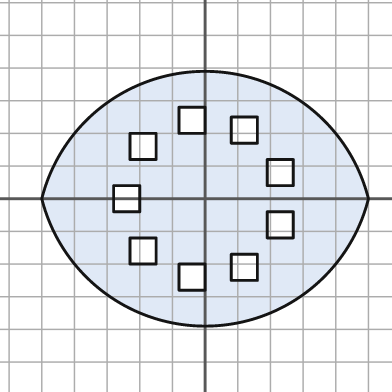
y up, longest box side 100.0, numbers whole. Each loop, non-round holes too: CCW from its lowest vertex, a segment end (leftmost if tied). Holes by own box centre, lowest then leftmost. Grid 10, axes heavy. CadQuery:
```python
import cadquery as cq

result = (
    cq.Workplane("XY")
    .moveTo(-50.0, 0.0)
    .threePointArc((0.0, -39.0), (50.0, 0.0))
    .threePointArc((0.0, 39.0), (-50.0, 0.0))
    .close()
    .moveTo(-8.0, -28.0)
    .lineTo(0.0, -28.0)
    .lineTo(0.0, -20.0)
    .lineTo(-8.0, -20.0)
    .close()
    .moveTo(8.0, -25.0)
    .lineTo(16.0, -25.0)
    .lineTo(16.0, -17.0)
    .lineTo(8.0, -17.0)
    .close()
    .moveTo(-23.0, -20.0)
    .lineTo(-15.0, -20.0)
    .lineTo(-15.0, -12.0)
    .lineTo(-23.0, -12.0)
    .close()
    .moveTo(19.0, -12.0)
    .lineTo(27.0, -12.0)
    .lineTo(27.0, -4.0)
    .lineTo(19.0, -4.0)
    .close()
    .moveTo(-28.0, -4.0)
    .lineTo(-20.0, -4.0)
    .lineTo(-20.0, 4.0)
    .lineTo(-28.0, 4.0)
    .close()
    .moveTo(19.0, 4.0)
    .lineTo(27.0, 4.0)
    .lineTo(27.0, 12.0)
    .lineTo(19.0, 12.0)
    .close()
    .moveTo(-23.0, 12.0)
    .lineTo(-15.0, 12.0)
    .lineTo(-15.0, 20.0)
    .lineTo(-23.0, 20.0)
    .close()
    .moveTo(8.0, 17.0)
    .lineTo(16.0, 17.0)
    .lineTo(16.0, 25.0)
    .lineTo(8.0, 25.0)
    .close()
    .moveTo(-8.0, 20.0)
    .lineTo(0.0, 20.0)
    .lineTo(0.0, 28.0)
    .lineTo(-8.0, 28.0)
    .close()
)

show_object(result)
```